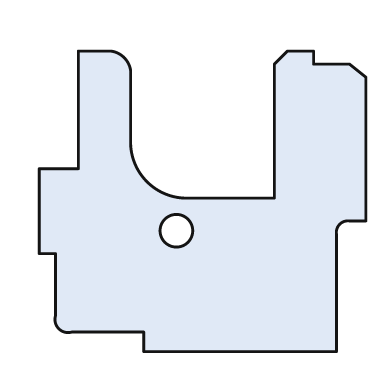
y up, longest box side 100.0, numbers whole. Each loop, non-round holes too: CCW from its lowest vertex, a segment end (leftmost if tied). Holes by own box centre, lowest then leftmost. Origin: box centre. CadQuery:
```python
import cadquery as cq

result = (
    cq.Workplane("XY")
    .moveTo(-18.0, -46.0)
    .lineTo(41.0, -46.0)
    .lineTo(41.0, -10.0)
    .threePointArc((42.0, -7.0), (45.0, -6.0))
    .lineTo(50.0, -6.0)
    .lineTo(50.0, 38.0)
    .lineTo(45.0, 42.0)
    .lineTo(34.0, 42.0)
    .lineTo(34.0, 46.0)
    .lineTo(26.0, 46.0)
    .lineTo(22.0, 42.0)
    .lineTo(22.0, 1.0)
    .lineTo(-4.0, 1.0)
    .threePointArc((-17.0, 6.0), (-22.0, 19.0))
    .lineTo(-22.0, 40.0)
    .threePointArc((-24.0, 44.0), (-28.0, 46.0))
    .lineTo(-38.0, 46.0)
    .lineTo(-38.0, 10.0)
    .lineTo(-50.0, 10.0)
    .lineTo(-50.0, -16.0)
    .lineTo(-45.0, -16.0)
    .lineTo(-45.0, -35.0)
    .threePointArc((-44.0, -39.0), (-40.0, -40.0))
    .lineTo(-18.0, -40.0)
    .close()
    .moveTo(-8.0, -9.0)
    .circle(5.0)
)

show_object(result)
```